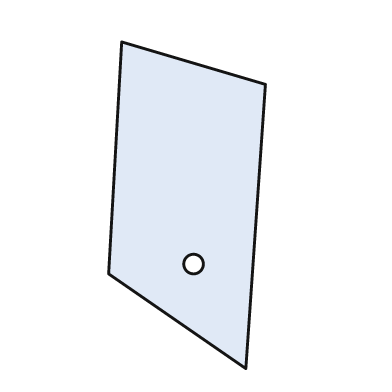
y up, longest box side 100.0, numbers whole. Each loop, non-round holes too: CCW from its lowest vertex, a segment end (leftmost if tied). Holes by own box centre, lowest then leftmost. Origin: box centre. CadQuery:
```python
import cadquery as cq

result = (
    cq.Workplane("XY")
    .moveTo(18.0, -50.0)
    .lineTo(24.0, 37.0)
    .lineTo(-20.0, 50.0)
    .lineTo(-24.0, -21.0)
    .close()
    .moveTo(2.0, -18.0)
    .circle(3.0)
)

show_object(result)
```